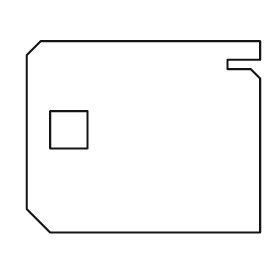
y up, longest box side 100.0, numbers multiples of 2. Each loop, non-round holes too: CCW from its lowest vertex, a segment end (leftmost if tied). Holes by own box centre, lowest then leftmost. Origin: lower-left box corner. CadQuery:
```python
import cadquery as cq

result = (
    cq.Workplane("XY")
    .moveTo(10.0, 0.0)
    .lineTo(100.0, 0.0)
    .lineTo(100.0, 66.0)
    .lineTo(96.0, 70.0)
    .lineTo(86.0, 70.0)
    .lineTo(86.0, 74.0)
    .lineTo(100.0, 74.0)
    .lineTo(100.0, 82.0)
    .lineTo(6.0, 82.0)
    .lineTo(0.0, 76.0)
    .lineTo(0.0, 10.0)
    .close()
    .moveTo(10.0, 36.0)
    .lineTo(26.0, 36.0)
    .lineTo(26.0, 52.0)
    .lineTo(10.0, 52.0)
    .close()
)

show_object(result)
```